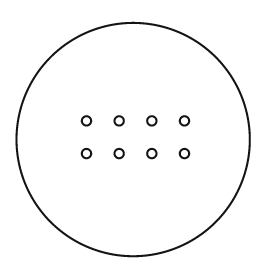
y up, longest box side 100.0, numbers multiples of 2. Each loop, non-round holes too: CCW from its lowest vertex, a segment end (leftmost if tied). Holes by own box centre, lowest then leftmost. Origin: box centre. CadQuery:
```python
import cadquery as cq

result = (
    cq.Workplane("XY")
    .moveTo(0.0, 0.0)
    .circle(50.0)
    .moveTo(-20.0, -6.0)
    .circle(2.0)
    .moveTo(-6.0, -6.0)
    .circle(2.0)
    .moveTo(8.0, -6.0)
    .circle(2.0)
    .moveTo(22.0, -6.0)
    .circle(2.0)
    .moveTo(-20.0, 8.0)
    .circle(2.0)
    .moveTo(-6.0, 8.0)
    .circle(2.0)
    .moveTo(8.0, 8.0)
    .circle(2.0)
    .moveTo(22.0, 8.0)
    .circle(2.0)
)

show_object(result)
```